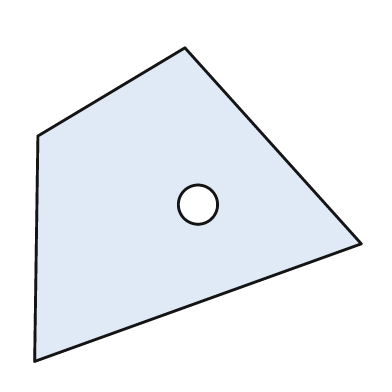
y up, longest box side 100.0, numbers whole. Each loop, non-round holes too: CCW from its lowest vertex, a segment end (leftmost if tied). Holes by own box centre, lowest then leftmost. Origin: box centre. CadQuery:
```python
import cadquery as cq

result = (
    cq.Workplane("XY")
    .moveTo(-50.0, -48.0)
    .lineTo(50.0, -12.0)
    .lineTo(-4.0, 48.0)
    .lineTo(-49.0, 21.0)
    .close()
    .moveTo(0.0, 0.0)
    .circle(6.0)
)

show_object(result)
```